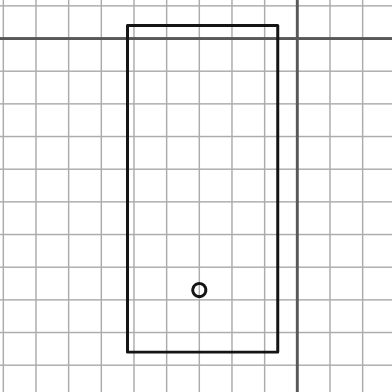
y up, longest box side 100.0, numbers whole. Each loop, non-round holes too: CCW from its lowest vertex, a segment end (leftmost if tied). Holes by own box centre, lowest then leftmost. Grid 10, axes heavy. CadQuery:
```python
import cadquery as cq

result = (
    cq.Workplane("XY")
    .moveTo(-52.0, -96.0)
    .lineTo(-6.0, -96.0)
    .lineTo(-6.0, 4.0)
    .lineTo(-52.0, 4.0)
    .close()
    .moveTo(-30.0, -77.0)
    .circle(2.0)
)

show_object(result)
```